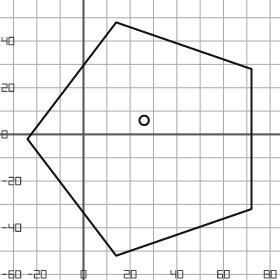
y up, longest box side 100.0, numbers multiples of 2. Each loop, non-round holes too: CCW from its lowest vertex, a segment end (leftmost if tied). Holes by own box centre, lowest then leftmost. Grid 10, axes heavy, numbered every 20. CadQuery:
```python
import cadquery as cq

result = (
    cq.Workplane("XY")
    .moveTo(14.0, -52.0)
    .lineTo(72.0, -32.0)
    .lineTo(72.0, 28.0)
    .lineTo(14.0, 48.0)
    .lineTo(-24.0, -2.0)
    .close()
    .moveTo(26.0, 6.0)
    .circle(2.0)
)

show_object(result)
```